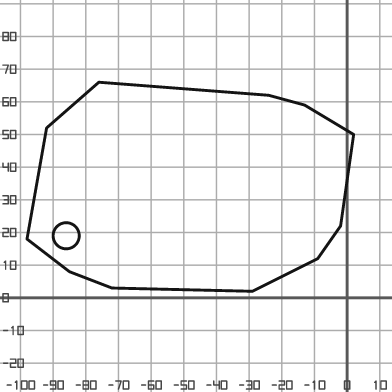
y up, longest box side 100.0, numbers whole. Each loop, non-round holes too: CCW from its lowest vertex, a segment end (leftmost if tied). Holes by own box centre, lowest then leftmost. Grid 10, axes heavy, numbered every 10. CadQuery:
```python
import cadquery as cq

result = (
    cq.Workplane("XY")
    .moveTo(-29.0, 2.0)
    .lineTo(-9.0, 12.0)
    .lineTo(-2.0, 22.0)
    .lineTo(2.0, 50.0)
    .lineTo(-13.0, 59.0)
    .lineTo(-24.0, 62.0)
    .lineTo(-76.0, 66.0)
    .lineTo(-92.0, 52.0)
    .lineTo(-98.0, 18.0)
    .lineTo(-85.0, 8.0)
    .lineTo(-72.0, 3.0)
    .close()
    .moveTo(-86.0, 19.0)
    .circle(4.0)
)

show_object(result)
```